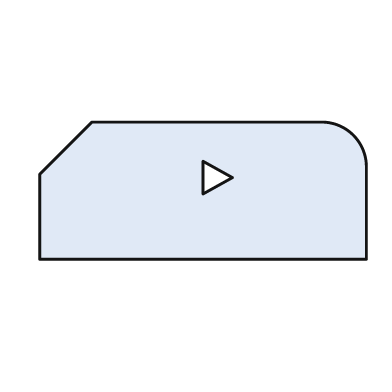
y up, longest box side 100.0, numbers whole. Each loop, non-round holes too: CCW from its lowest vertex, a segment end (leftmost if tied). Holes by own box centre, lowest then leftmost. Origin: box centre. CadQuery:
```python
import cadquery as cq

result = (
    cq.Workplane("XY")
    .moveTo(-50.0, -21.0)
    .lineTo(50.0, -21.0)
    .lineTo(50.0, 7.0)
    .threePointArc((46.0, 17.0), (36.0, 21.0))
    .lineTo(-34.0, 21.0)
    .lineTo(-50.0, 5.0)
    .close()
    .moveTo(0.0, -1.0)
    .lineTo(9.0, 4.0)
    .lineTo(0.0, 9.0)
    .close()
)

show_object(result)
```